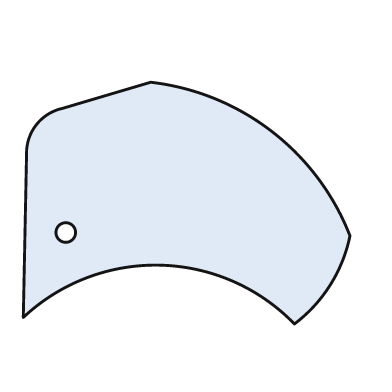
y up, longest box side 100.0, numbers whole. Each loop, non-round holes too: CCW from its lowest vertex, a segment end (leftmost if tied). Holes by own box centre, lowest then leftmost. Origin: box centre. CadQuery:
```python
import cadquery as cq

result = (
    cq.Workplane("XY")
    .moveTo(33.0, -37.0)
    .threePointArc((44.0, -25.0), (50.0, -10.0))
    .threePointArc((26.0, 22.0), (-11.0, 37.0))
    .lineTo(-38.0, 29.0)
    .threePointArc((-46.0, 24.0), (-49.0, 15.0))
    .lineTo(-50.0, -35.0)
    .threePointArc((-8.0, -19.0), (33.0, -37.0))
    .close()
    .moveTo(-37.0, -9.0)
    .circle(3.0)
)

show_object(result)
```